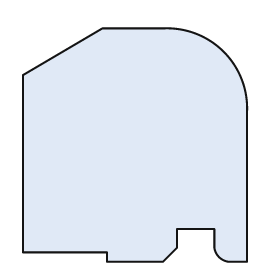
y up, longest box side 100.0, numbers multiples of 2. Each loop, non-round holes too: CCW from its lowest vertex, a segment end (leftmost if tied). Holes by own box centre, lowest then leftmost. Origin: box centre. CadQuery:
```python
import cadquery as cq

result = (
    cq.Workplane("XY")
    .moveTo(-12.0, -50.0)
    .lineTo(12.0, -50.0)
    .lineTo(18.0, -44.0)
    .lineTo(18.0, -36.0)
    .lineTo(34.0, -36.0)
    .lineTo(34.0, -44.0)
    .threePointArc((36.0, -48.0), (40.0, -50.0))
    .lineTo(48.0, -50.0)
    .lineTo(48.0, 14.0)
    .threePointArc((38.0, 40.0), (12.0, 50.0))
    .lineTo(-14.0, 50.0)
    .lineTo(-48.0, 30.0)
    .lineTo(-48.0, -46.0)
    .lineTo(-12.0, -46.0)
    .close()
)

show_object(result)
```